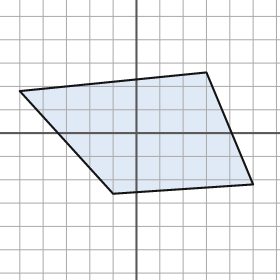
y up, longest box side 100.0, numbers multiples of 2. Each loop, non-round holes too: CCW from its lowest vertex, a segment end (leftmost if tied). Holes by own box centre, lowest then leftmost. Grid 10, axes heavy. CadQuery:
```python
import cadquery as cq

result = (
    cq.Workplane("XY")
    .moveTo(-10.0, -26.0)
    .lineTo(50.0, -22.0)
    .lineTo(30.0, 26.0)
    .lineTo(-50.0, 18.0)
    .close()
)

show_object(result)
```